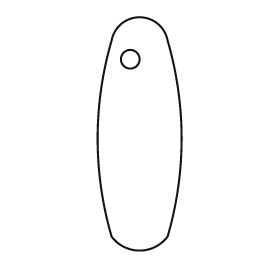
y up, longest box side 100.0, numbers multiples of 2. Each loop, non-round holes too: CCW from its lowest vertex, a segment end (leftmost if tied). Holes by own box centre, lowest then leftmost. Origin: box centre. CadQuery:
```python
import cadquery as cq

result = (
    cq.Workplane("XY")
    .moveTo(-12.0, -44.0)
    .threePointArc((0.0, -50.0), (12.0, -44.0))
    .threePointArc((18.0, -2.0), (12.0, 40.0))
    .threePointArc((0.0, 50.0), (-12.0, 40.0))
    .threePointArc((-18.0, -2.0), (-12.0, -44.0))
    .close()
    .moveTo(-4.0, 32.0)
    .circle(4.0)
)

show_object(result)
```